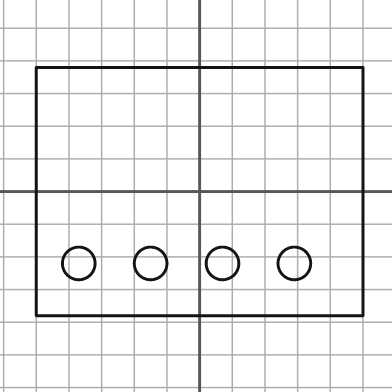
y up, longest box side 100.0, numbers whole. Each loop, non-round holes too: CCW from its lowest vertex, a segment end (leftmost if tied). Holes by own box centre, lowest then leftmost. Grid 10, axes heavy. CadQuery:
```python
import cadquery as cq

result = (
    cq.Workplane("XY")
    .moveTo(-50.0, -38.0)
    .lineTo(50.0, -38.0)
    .lineTo(50.0, 38.0)
    .lineTo(-50.0, 38.0)
    .close()
    .moveTo(-37.0, -22.0)
    .circle(5.0)
    .moveTo(-15.0, -22.0)
    .circle(5.0)
    .moveTo(7.0, -22.0)
    .circle(5.0)
    .moveTo(29.0, -22.0)
    .circle(5.0)
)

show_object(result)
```